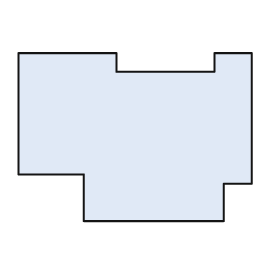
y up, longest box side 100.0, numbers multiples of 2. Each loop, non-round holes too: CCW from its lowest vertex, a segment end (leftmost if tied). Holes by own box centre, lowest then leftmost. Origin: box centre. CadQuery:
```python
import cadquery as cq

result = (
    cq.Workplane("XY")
    .moveTo(-22.0, -36.0)
    .lineTo(38.0, -36.0)
    .lineTo(38.0, -20.0)
    .lineTo(50.0, -20.0)
    .lineTo(50.0, 36.0)
    .lineTo(34.0, 36.0)
    .lineTo(34.0, 28.0)
    .lineTo(-8.0, 28.0)
    .lineTo(-8.0, 36.0)
    .lineTo(-50.0, 36.0)
    .lineTo(-50.0, -16.0)
    .lineTo(-22.0, -16.0)
    .close()
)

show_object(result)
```